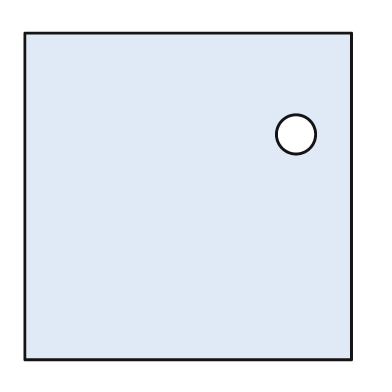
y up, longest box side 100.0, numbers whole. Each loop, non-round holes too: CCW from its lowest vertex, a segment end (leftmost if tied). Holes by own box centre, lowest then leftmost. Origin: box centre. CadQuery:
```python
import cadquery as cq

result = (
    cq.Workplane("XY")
    .moveTo(-50.0, -50.0)
    .lineTo(50.0, -50.0)
    .lineTo(50.0, 50.0)
    .lineTo(-50.0, 50.0)
    .close()
    .moveTo(33.0, 19.0)
    .circle(6.0)
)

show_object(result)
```